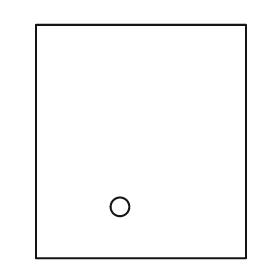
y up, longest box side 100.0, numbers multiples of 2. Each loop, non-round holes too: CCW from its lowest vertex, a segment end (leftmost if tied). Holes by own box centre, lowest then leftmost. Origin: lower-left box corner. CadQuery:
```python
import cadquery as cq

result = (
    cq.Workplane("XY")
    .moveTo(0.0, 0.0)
    .lineTo(90.0, 0.0)
    .lineTo(90.0, 100.0)
    .lineTo(0.0, 100.0)
    .close()
    .moveTo(36.0, 22.0)
    .circle(4.0)
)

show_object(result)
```